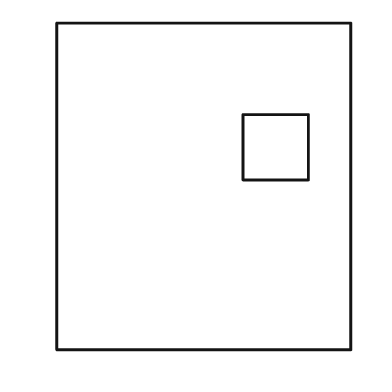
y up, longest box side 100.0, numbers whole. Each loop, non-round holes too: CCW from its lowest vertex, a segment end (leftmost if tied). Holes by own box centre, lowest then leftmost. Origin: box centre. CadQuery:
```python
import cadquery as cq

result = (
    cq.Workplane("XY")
    .moveTo(-45.0, -50.0)
    .lineTo(45.0, -50.0)
    .lineTo(45.0, 50.0)
    .lineTo(-45.0, 50.0)
    .close()
    .moveTo(12.0, 2.0)
    .lineTo(32.0, 2.0)
    .lineTo(32.0, 22.0)
    .lineTo(12.0, 22.0)
    .close()
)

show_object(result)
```